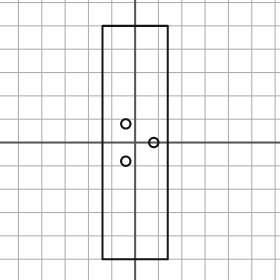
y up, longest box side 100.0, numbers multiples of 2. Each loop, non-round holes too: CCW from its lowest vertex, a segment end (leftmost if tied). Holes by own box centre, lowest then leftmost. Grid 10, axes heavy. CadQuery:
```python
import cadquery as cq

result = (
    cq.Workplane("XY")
    .moveTo(-14.0, -50.0)
    .lineTo(14.0, -50.0)
    .lineTo(14.0, 50.0)
    .lineTo(-14.0, 50.0)
    .close()
    .moveTo(-4.0, -8.0)
    .circle(2.0)
    .moveTo(8.0, 0.0)
    .circle(2.0)
    .moveTo(-4.0, 8.0)
    .circle(2.0)
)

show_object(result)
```